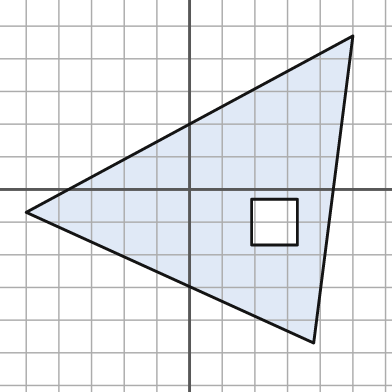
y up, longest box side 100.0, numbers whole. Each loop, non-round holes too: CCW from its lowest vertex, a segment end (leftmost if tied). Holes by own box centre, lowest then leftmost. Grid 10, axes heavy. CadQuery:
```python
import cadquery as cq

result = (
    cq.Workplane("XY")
    .moveTo(38.0, -47.0)
    .lineTo(50.0, 47.0)
    .lineTo(-50.0, -7.0)
    .close()
    .moveTo(19.0, -17.0)
    .lineTo(33.0, -17.0)
    .lineTo(33.0, -3.0)
    .lineTo(19.0, -3.0)
    .close()
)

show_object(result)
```